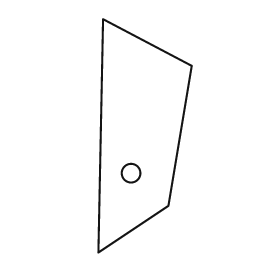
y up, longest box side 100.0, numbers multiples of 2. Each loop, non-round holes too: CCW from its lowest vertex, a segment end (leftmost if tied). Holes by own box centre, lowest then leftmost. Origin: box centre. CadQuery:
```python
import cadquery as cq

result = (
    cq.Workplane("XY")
    .moveTo(-20.0, -50.0)
    .lineTo(10.0, -30.0)
    .lineTo(20.0, 30.0)
    .lineTo(-18.0, 50.0)
    .close()
    .moveTo(-6.0, -16.0)
    .circle(4.0)
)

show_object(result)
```